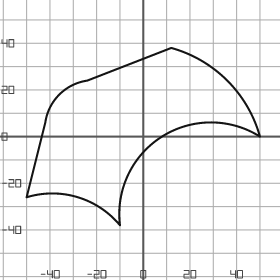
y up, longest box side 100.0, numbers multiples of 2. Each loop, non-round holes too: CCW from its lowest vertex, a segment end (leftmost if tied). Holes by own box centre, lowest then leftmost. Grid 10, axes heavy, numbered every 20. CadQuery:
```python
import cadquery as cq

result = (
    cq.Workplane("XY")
    .moveTo(-10.0, -38.0)
    .threePointArc((8.0, 0.0), (50.0, 0.0))
    .threePointArc((36.0, 24.0), (12.0, 38.0))
    .lineTo(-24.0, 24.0)
    .threePointArc((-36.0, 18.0), (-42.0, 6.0))
    .lineTo(-50.0, -26.0)
    .threePointArc((-28.0, -26.0), (-10.0, -38.0))
    .close()
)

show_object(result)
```